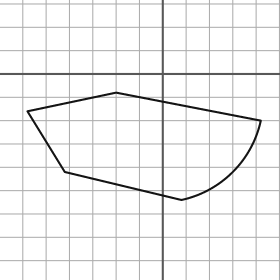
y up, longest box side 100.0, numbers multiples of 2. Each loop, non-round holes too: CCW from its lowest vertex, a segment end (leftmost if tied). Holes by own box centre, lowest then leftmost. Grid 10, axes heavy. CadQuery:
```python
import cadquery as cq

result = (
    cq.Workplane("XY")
    .moveTo(8.0, -54.0)
    .threePointArc((30.0, -42.0), (42.0, -20.0))
    .lineTo(-20.0, -8.0)
    .lineTo(-58.0, -16.0)
    .lineTo(-42.0, -42.0)
    .close()
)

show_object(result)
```